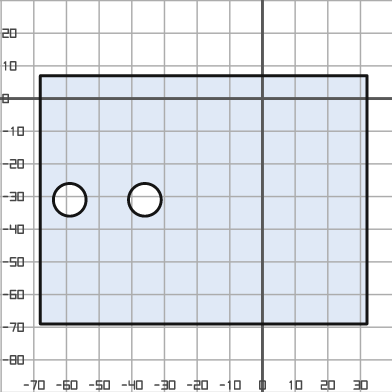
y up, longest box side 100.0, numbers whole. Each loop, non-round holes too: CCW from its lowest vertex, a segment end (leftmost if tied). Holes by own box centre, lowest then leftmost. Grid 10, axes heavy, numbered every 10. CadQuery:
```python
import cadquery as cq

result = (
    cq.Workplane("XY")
    .moveTo(-68.0, -69.0)
    .lineTo(32.0, -69.0)
    .lineTo(32.0, 7.0)
    .lineTo(-68.0, 7.0)
    .close()
    .moveTo(-59.0, -31.0)
    .circle(5.0)
    .moveTo(-36.0, -31.0)
    .circle(5.0)
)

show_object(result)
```